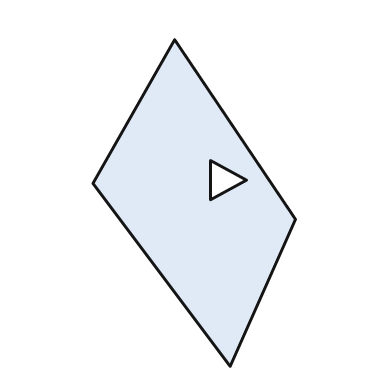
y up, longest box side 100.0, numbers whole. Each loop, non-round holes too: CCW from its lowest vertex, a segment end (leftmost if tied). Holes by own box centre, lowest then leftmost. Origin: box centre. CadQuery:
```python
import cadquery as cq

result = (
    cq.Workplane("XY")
    .moveTo(11.0, -50.0)
    .lineTo(31.0, -5.0)
    .lineTo(-6.0, 50.0)
    .lineTo(-31.0, 6.0)
    .close()
    .moveTo(5.0, 1.0)
    .lineTo(16.0, 7.0)
    .lineTo(5.0, 13.0)
    .close()
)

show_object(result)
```